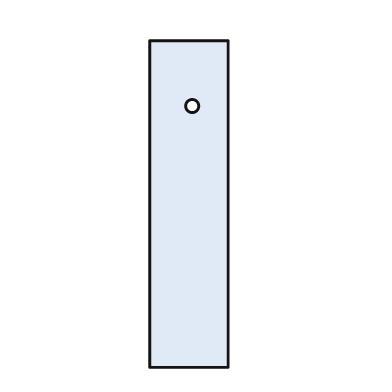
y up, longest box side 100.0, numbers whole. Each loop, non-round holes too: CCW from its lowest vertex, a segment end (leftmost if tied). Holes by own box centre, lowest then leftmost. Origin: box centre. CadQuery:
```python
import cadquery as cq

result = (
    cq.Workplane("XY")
    .moveTo(-12.0, -50.0)
    .lineTo(12.0, -50.0)
    .lineTo(12.0, 50.0)
    .lineTo(-12.0, 50.0)
    .close()
    .moveTo(1.0, 30.0)
    .circle(2.0)
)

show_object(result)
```